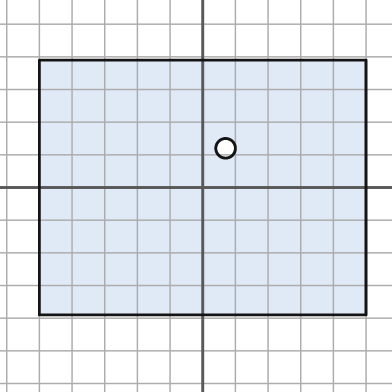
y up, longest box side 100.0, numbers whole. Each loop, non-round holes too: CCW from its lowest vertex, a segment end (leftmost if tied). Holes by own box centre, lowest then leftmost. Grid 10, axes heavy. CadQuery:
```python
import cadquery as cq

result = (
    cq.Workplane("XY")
    .moveTo(-50.0, -39.0)
    .lineTo(50.0, -39.0)
    .lineTo(50.0, 39.0)
    .lineTo(-50.0, 39.0)
    .close()
    .moveTo(7.0, 12.0)
    .circle(3.0)
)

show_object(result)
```